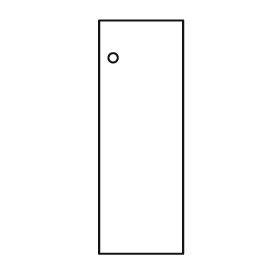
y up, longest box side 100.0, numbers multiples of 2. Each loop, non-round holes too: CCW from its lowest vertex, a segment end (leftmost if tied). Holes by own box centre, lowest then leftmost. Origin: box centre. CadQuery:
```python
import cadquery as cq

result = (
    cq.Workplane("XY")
    .moveTo(-18.0, -50.0)
    .lineTo(18.0, -50.0)
    .lineTo(18.0, 50.0)
    .lineTo(-18.0, 50.0)
    .close()
    .moveTo(-12.0, 34.0)
    .circle(2.0)
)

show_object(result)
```